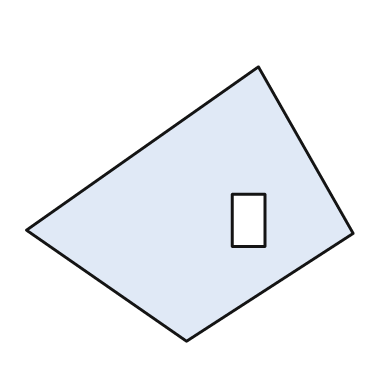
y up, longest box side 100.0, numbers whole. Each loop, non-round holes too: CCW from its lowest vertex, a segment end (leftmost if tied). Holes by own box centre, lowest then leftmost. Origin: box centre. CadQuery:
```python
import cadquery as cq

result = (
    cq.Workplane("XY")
    .moveTo(-1.0, -42.0)
    .lineTo(50.0, -9.0)
    .lineTo(21.0, 42.0)
    .lineTo(-50.0, -8.0)
    .close()
    .moveTo(13.0, -13.0)
    .lineTo(23.0, -13.0)
    .lineTo(23.0, 3.0)
    .lineTo(13.0, 3.0)
    .close()
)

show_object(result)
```